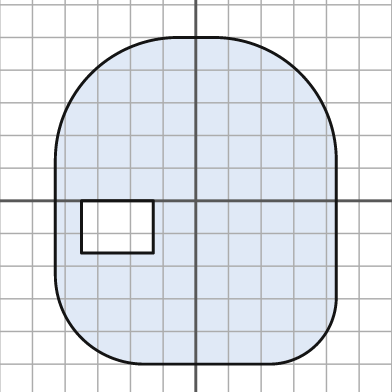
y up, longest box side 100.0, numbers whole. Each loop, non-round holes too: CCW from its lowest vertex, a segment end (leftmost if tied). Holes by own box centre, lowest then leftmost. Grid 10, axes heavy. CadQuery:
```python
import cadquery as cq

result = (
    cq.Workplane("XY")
    .moveTo(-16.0, -50.0)
    .lineTo(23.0, -50.0)
    .threePointArc((37.0, -44.0), (43.0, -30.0))
    .lineTo(43.0, 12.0)
    .threePointArc((32.0, 39.0), (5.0, 50.0))
    .lineTo(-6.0, 50.0)
    .threePointArc((-32.0, 39.0), (-43.0, 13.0))
    .lineTo(-43.0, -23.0)
    .threePointArc((-35.0, -42.0), (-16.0, -50.0))
    .close()
    .moveTo(-35.0, -16.0)
    .lineTo(-13.0, -16.0)
    .lineTo(-13.0, 0.0)
    .lineTo(-35.0, 0.0)
    .close()
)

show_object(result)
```